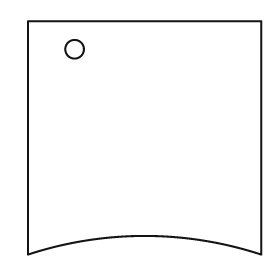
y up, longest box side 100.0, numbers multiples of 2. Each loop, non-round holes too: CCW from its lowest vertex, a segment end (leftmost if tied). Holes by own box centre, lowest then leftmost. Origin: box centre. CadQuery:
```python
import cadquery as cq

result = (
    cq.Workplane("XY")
    .moveTo(-50.0, -50.0)
    .threePointArc((0.0, -42.0), (50.0, -50.0))
    .lineTo(50.0, 50.0)
    .lineTo(-50.0, 50.0)
    .close()
    .moveTo(-30.0, 38.0)
    .circle(4.0)
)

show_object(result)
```